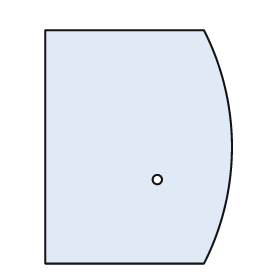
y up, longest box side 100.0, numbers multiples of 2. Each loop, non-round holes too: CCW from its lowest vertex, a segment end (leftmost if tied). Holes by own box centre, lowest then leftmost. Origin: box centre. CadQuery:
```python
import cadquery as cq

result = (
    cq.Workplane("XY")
    .moveTo(-40.0, -50.0)
    .lineTo(28.0, -50.0)
    .threePointArc((40.0, 0.0), (28.0, 50.0))
    .lineTo(-40.0, 50.0)
    .close()
    .moveTo(8.0, -14.0)
    .circle(2.0)
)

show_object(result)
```